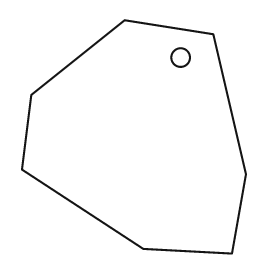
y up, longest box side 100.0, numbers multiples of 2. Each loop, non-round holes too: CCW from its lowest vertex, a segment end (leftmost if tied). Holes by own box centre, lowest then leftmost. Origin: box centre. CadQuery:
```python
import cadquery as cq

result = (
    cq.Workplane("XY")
    .moveTo(42.0, -50.0)
    .lineTo(48.0, -16.0)
    .lineTo(34.0, 44.0)
    .lineTo(-4.0, 50.0)
    .lineTo(-44.0, 18.0)
    .lineTo(-48.0, -14.0)
    .lineTo(4.0, -48.0)
    .close()
    .moveTo(20.0, 34.0)
    .circle(4.0)
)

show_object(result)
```